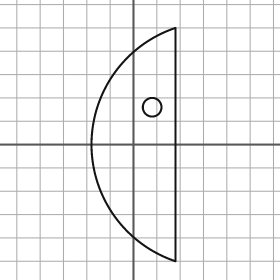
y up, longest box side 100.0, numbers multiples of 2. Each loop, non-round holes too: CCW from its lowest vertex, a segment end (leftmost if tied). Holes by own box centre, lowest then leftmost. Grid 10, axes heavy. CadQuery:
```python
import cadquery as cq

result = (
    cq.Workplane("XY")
    .moveTo(18.0, -50.0)
    .lineTo(18.0, 50.0)
    .threePointArc((-18.0, 0.0), (18.0, -50.0))
    .close()
    .moveTo(8.0, 16.0)
    .circle(4.0)
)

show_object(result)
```